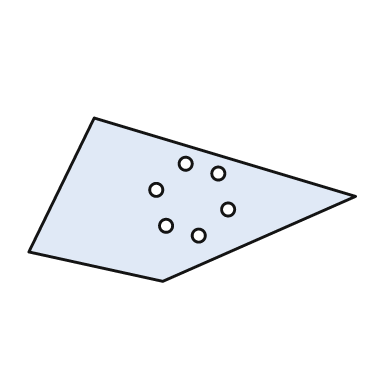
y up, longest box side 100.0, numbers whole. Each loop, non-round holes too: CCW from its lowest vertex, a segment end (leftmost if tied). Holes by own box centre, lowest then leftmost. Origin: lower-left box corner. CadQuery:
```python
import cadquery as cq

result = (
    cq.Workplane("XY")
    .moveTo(41.0, 0.0)
    .lineTo(100.0, 26.0)
    .lineTo(20.0, 50.0)
    .lineTo(0.0, 9.0)
    .close()
    .moveTo(52.0, 14.0)
    .circle(2.0)
    .moveTo(42.0, 17.0)
    .circle(2.0)
    .moveTo(61.0, 22.0)
    .circle(2.0)
    .moveTo(39.0, 28.0)
    .circle(2.0)
    .moveTo(58.0, 33.0)
    .circle(2.0)
    .moveTo(48.0, 36.0)
    .circle(2.0)
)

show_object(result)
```